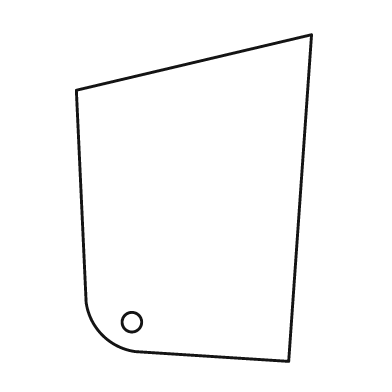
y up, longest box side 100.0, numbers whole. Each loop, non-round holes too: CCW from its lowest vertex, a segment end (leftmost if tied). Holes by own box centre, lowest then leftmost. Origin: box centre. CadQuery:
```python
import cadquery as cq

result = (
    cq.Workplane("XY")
    .moveTo(29.0, -50.0)
    .lineTo(36.0, 50.0)
    .lineTo(-36.0, 33.0)
    .lineTo(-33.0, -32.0)
    .threePointArc((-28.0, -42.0), (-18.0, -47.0))
    .close()
    .moveTo(-19.0, -38.0)
    .circle(3.0)
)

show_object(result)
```